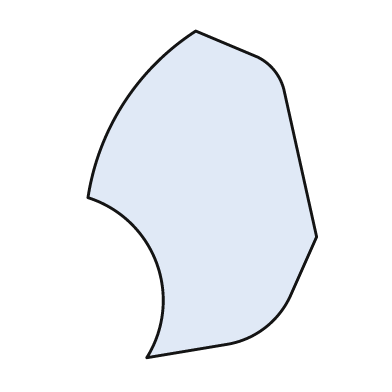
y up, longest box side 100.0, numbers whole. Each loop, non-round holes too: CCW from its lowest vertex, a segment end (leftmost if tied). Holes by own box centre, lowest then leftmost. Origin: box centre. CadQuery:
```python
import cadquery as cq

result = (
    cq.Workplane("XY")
    .moveTo(-17.0, -50.0)
    .lineTo(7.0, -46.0)
    .threePointArc((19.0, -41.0), (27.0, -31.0))
    .lineTo(35.0, -13.0)
    .lineTo(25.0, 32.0)
    .threePointArc((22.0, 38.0), (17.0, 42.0))
    .lineTo(-2.0, 50.0)
    .threePointArc((-24.0, 28.0), (-35.0, -1.0))
    .threePointArc((-14.0, -21.0), (-17.0, -50.0))
    .close()
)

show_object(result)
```